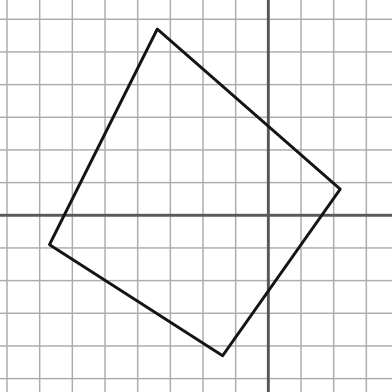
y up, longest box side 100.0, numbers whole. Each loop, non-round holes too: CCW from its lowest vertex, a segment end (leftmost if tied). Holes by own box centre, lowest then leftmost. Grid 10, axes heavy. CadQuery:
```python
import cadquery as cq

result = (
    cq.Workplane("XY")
    .moveTo(-14.0, -43.0)
    .lineTo(22.0, 8.0)
    .lineTo(-34.0, 57.0)
    .lineTo(-67.0, -9.0)
    .close()
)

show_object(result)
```